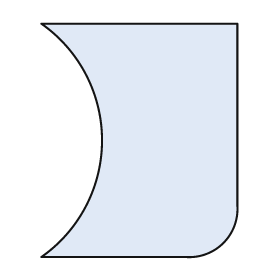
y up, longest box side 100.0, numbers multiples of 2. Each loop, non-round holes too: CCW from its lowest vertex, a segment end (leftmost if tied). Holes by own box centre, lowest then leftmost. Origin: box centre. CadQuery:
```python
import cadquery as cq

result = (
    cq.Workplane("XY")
    .moveTo(-42.0, -50.0)
    .lineTo(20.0, -50.0)
    .threePointArc((36.0, -44.0), (42.0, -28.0))
    .lineTo(42.0, 50.0)
    .lineTo(-42.0, 50.0)
    .threePointArc((-16.0, 0.0), (-42.0, -50.0))
    .close()
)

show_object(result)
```